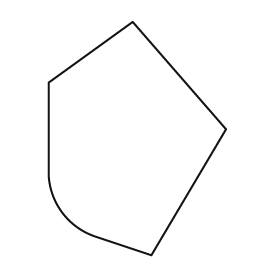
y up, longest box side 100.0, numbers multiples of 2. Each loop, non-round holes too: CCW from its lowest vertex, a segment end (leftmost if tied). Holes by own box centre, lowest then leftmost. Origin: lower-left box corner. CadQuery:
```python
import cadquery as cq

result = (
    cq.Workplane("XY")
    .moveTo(44.0, 0.0)
    .lineTo(76.0, 54.0)
    .lineTo(36.0, 100.0)
    .lineTo(0.0, 74.0)
    .lineTo(0.0, 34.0)
    .threePointArc((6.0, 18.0), (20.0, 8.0))
    .close()
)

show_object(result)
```